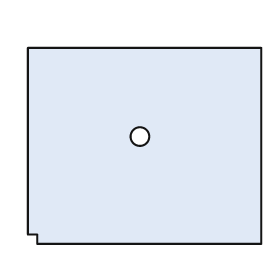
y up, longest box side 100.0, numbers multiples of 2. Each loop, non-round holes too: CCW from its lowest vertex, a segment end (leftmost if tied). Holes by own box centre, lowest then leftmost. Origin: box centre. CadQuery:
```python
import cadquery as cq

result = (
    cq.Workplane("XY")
    .moveTo(-46.0, -42.0)
    .lineTo(50.0, -42.0)
    .lineTo(50.0, 42.0)
    .lineTo(-50.0, 42.0)
    .lineTo(-50.0, -38.0)
    .lineTo(-46.0, -38.0)
    .close()
    .moveTo(-2.0, 4.0)
    .circle(4.0)
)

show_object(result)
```